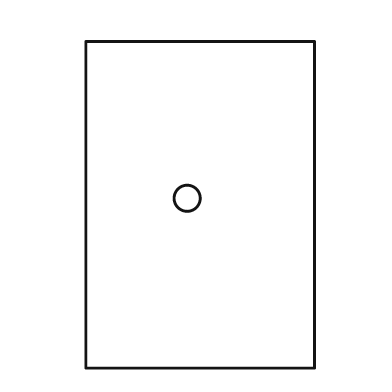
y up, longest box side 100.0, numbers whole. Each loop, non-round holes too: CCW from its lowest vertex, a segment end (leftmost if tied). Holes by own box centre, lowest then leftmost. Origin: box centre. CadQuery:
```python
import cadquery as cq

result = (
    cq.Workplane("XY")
    .moveTo(-35.0, -50.0)
    .lineTo(35.0, -50.0)
    .lineTo(35.0, 50.0)
    .lineTo(-35.0, 50.0)
    .close()
    .moveTo(-4.0, 2.0)
    .circle(4.0)
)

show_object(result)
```